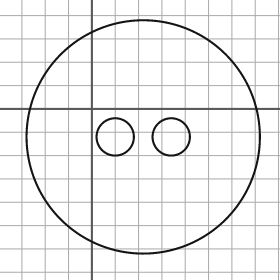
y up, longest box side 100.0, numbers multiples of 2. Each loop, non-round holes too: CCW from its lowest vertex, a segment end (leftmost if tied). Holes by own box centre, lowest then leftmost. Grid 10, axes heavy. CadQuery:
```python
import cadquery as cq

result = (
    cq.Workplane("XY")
    .moveTo(22.0, -12.0)
    .circle(50.0)
    .moveTo(10.0, -12.0)
    .circle(8.0)
    .moveTo(34.0, -12.0)
    .circle(8.0)
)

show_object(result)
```